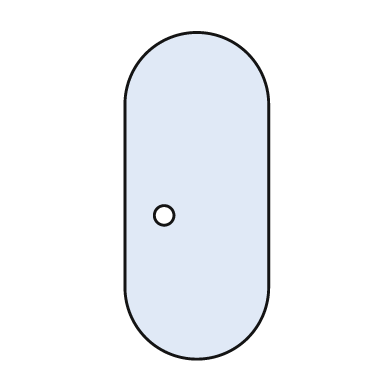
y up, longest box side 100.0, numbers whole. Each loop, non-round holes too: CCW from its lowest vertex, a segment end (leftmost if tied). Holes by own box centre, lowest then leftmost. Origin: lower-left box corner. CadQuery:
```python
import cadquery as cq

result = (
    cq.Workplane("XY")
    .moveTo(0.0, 22.0)
    .threePointArc((22.0, 0.0), (44.0, 22.0))
    .lineTo(44.0, 78.0)
    .threePointArc((22.0, 100.0), (0.0, 78.0))
    .close()
    .moveTo(12.0, 44.0)
    .circle(3.0)
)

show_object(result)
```